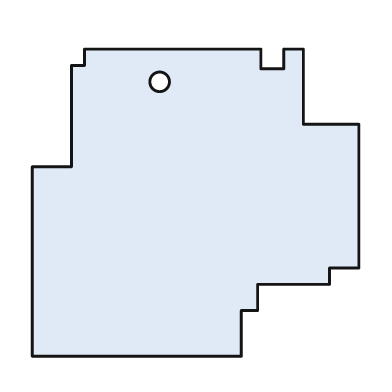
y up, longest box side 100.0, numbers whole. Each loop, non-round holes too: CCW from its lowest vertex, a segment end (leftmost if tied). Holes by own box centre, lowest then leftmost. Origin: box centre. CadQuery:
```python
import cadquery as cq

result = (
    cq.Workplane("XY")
    .moveTo(-50.0, -47.0)
    .lineTo(14.0, -47.0)
    .lineTo(14.0, -33.0)
    .lineTo(19.0, -33.0)
    .lineTo(19.0, -25.0)
    .lineTo(41.0, -25.0)
    .lineTo(41.0, -20.0)
    .lineTo(50.0, -20.0)
    .lineTo(50.0, 24.0)
    .lineTo(33.0, 24.0)
    .lineTo(33.0, 47.0)
    .lineTo(27.0, 47.0)
    .lineTo(27.0, 41.0)
    .lineTo(20.0, 41.0)
    .lineTo(20.0, 47.0)
    .lineTo(-34.0, 47.0)
    .lineTo(-34.0, 42.0)
    .lineTo(-38.0, 42.0)
    .lineTo(-38.0, 11.0)
    .lineTo(-50.0, 11.0)
    .close()
    .moveTo(-11.0, 37.0)
    .circle(3.0)
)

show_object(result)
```